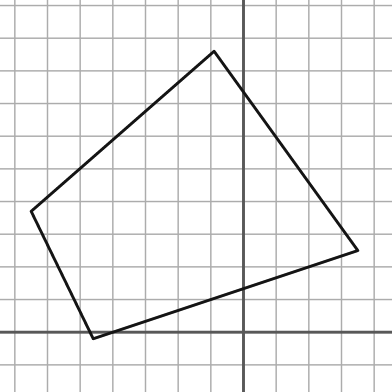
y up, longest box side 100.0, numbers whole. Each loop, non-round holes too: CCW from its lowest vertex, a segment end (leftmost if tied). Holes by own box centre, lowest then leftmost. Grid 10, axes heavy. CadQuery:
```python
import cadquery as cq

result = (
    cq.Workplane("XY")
    .moveTo(-46.0, -2.0)
    .lineTo(35.0, 25.0)
    .lineTo(-9.0, 86.0)
    .lineTo(-65.0, 37.0)
    .close()
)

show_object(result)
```